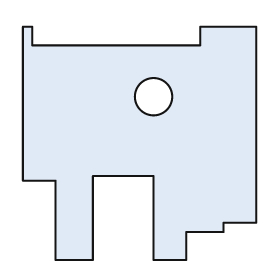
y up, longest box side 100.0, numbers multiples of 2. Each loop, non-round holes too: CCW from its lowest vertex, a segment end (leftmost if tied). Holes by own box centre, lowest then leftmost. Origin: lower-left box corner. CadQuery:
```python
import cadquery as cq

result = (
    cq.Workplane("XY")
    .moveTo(14.0, 0.0)
    .lineTo(30.0, 0.0)
    .lineTo(30.0, 36.0)
    .lineTo(56.0, 36.0)
    .lineTo(56.0, 0.0)
    .lineTo(70.0, 0.0)
    .lineTo(70.0, 12.0)
    .lineTo(86.0, 12.0)
    .lineTo(86.0, 16.0)
    .lineTo(100.0, 16.0)
    .lineTo(100.0, 100.0)
    .lineTo(76.0, 100.0)
    .lineTo(76.0, 92.0)
    .lineTo(4.0, 92.0)
    .lineTo(4.0, 100.0)
    .lineTo(0.0, 100.0)
    .lineTo(0.0, 34.0)
    .lineTo(14.0, 34.0)
    .close()
    .moveTo(56.0, 70.0)
    .circle(8.0)
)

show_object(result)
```